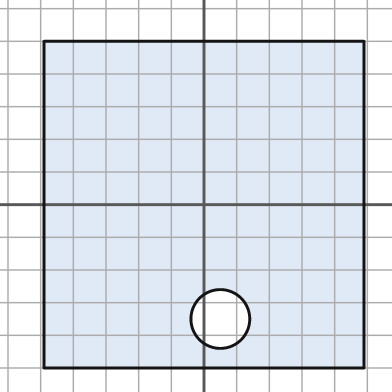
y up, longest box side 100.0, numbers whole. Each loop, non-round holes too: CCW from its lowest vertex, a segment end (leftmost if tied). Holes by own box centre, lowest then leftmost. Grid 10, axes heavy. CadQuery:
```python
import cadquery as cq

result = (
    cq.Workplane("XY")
    .moveTo(-49.0, -50.0)
    .lineTo(49.0, -50.0)
    .lineTo(49.0, 50.0)
    .lineTo(-49.0, 50.0)
    .close()
    .moveTo(5.0, -35.0)
    .circle(9.0)
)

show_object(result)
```